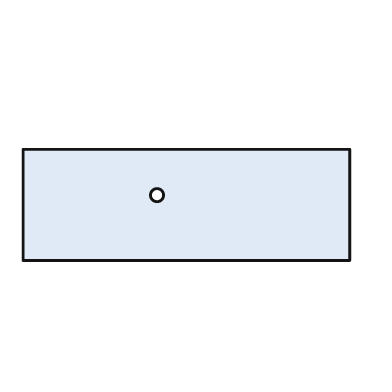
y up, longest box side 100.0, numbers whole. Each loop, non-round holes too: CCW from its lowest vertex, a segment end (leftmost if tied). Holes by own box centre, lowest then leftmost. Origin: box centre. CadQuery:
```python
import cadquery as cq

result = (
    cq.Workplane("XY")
    .moveTo(-50.0, -17.0)
    .lineTo(50.0, -17.0)
    .lineTo(50.0, 17.0)
    .lineTo(-50.0, 17.0)
    .close()
    .moveTo(-9.0, 3.0)
    .circle(2.0)
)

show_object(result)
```